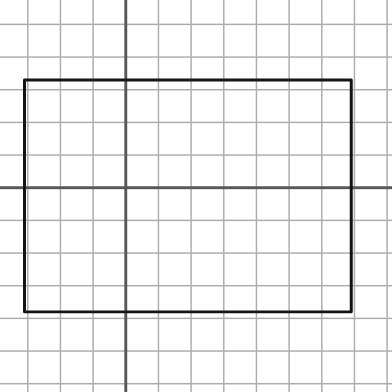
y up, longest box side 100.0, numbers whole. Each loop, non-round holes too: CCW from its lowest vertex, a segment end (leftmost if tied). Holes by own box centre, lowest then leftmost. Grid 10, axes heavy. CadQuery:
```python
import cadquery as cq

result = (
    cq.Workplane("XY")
    .moveTo(-31.0, -38.0)
    .lineTo(69.0, -38.0)
    .lineTo(69.0, 33.0)
    .lineTo(-31.0, 33.0)
    .close()
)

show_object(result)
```